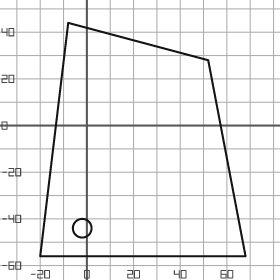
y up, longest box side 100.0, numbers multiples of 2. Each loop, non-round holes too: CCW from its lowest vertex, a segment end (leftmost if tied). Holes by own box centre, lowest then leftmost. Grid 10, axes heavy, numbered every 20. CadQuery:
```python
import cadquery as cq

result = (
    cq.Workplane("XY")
    .moveTo(-20.0, -56.0)
    .lineTo(68.0, -56.0)
    .lineTo(52.0, 28.0)
    .lineTo(-8.0, 44.0)
    .close()
    .moveTo(-2.0, -44.0)
    .circle(4.0)
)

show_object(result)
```